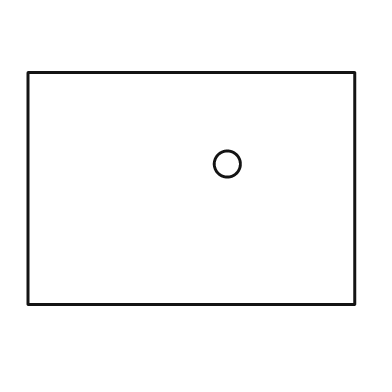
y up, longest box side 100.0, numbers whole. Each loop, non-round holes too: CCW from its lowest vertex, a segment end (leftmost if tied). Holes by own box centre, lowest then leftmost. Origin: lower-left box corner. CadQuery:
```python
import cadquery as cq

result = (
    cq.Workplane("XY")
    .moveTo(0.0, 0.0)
    .lineTo(100.0, 0.0)
    .lineTo(100.0, 71.0)
    .lineTo(0.0, 71.0)
    .close()
    .moveTo(61.0, 43.0)
    .circle(4.0)
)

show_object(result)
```